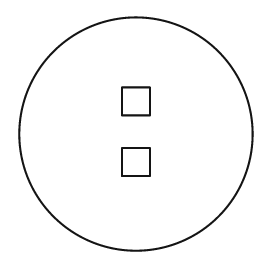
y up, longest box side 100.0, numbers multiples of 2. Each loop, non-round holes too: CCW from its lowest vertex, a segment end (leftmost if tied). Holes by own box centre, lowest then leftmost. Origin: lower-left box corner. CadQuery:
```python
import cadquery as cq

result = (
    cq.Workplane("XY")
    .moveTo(50.0, 50.0)
    .circle(50.0)
    .moveTo(44.0, 32.0)
    .lineTo(56.0, 32.0)
    .lineTo(56.0, 44.0)
    .lineTo(44.0, 44.0)
    .close()
    .moveTo(44.0, 58.0)
    .lineTo(56.0, 58.0)
    .lineTo(56.0, 70.0)
    .lineTo(44.0, 70.0)
    .close()
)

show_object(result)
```